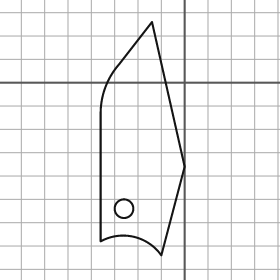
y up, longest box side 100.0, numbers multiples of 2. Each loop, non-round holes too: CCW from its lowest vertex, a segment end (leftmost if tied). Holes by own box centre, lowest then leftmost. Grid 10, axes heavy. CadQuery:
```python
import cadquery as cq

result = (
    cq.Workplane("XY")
    .moveTo(-10.0, -74.0)
    .lineTo(0.0, -36.0)
    .lineTo(-14.0, 26.0)
    .lineTo(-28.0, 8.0)
    .threePointArc((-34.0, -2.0), (-36.0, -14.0))
    .lineTo(-36.0, -68.0)
    .threePointArc((-22.0, -66.0), (-10.0, -74.0))
    .close()
    .moveTo(-26.0, -54.0)
    .circle(4.0)
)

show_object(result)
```